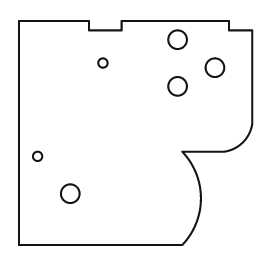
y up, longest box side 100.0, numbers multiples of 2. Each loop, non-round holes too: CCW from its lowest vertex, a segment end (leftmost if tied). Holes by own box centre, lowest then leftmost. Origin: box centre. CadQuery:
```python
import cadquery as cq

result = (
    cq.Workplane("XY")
    .moveTo(-50.0, -48.0)
    .lineTo(20.0, -48.0)
    .threePointArc((28.0, -28.0), (20.0, -8.0))
    .lineTo(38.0, -8.0)
    .threePointArc((46.0, -4.0), (50.0, 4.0))
    .lineTo(50.0, 44.0)
    .lineTo(40.0, 44.0)
    .lineTo(40.0, 48.0)
    .lineTo(-6.0, 48.0)
    .lineTo(-6.0, 44.0)
    .lineTo(-20.0, 44.0)
    .lineTo(-20.0, 48.0)
    .lineTo(-50.0, 48.0)
    .close()
    .moveTo(-28.0, -26.0)
    .circle(4.0)
    .moveTo(-42.0, -10.0)
    .circle(2.0)
    .moveTo(18.0, 20.0)
    .circle(4.0)
    .moveTo(34.0, 28.0)
    .circle(4.0)
    .moveTo(-14.0, 30.0)
    .circle(2.0)
    .moveTo(18.0, 40.0)
    .circle(4.0)
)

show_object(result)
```